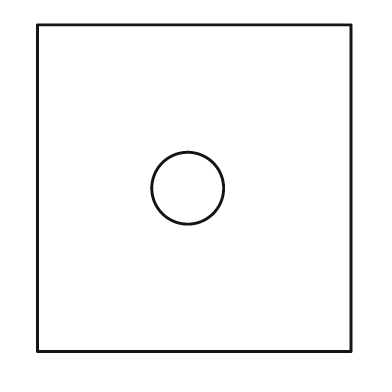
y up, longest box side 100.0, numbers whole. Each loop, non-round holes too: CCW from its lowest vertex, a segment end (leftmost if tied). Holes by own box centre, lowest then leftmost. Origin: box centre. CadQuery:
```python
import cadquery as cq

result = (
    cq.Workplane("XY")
    .moveTo(-48.0, -50.0)
    .lineTo(48.0, -50.0)
    .lineTo(48.0, 50.0)
    .lineTo(-48.0, 50.0)
    .close()
    .moveTo(-2.0, 0.0)
    .circle(11.0)
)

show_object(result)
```